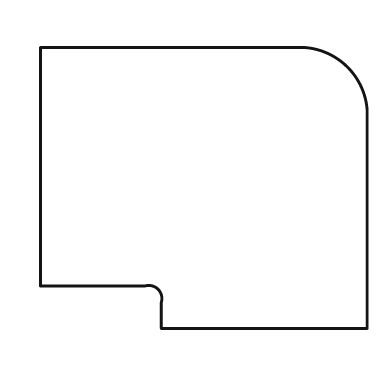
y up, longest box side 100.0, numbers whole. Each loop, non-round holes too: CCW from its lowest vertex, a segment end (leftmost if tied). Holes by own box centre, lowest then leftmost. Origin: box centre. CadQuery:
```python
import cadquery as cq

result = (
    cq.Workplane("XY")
    .moveTo(-13.0, -43.0)
    .lineTo(50.0, -43.0)
    .lineTo(50.0, 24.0)
    .threePointArc((44.0, 37.0), (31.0, 43.0))
    .lineTo(-50.0, 43.0)
    .lineTo(-50.0, -30.0)
    .lineTo(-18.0, -30.0)
    .threePointArc((-14.0, -31.0), (-13.0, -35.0))
    .close()
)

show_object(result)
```